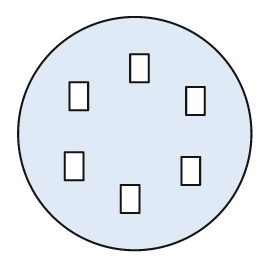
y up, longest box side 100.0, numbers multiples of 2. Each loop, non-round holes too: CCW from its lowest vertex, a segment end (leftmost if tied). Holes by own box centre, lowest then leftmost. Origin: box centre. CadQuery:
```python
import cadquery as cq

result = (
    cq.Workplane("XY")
    .moveTo(0.0, 0.0)
    .circle(50.0)
    .moveTo(-6.0, -34.0)
    .lineTo(2.0, -34.0)
    .lineTo(2.0, -22.0)
    .lineTo(-6.0, -22.0)
    .close()
    .moveTo(20.0, -22.0)
    .lineTo(28.0, -22.0)
    .lineTo(28.0, -10.0)
    .lineTo(20.0, -10.0)
    .close()
    .moveTo(-30.0, -20.0)
    .lineTo(-22.0, -20.0)
    .lineTo(-22.0, -8.0)
    .lineTo(-30.0, -8.0)
    .close()
    .moveTo(22.0, 8.0)
    .lineTo(30.0, 8.0)
    .lineTo(30.0, 20.0)
    .lineTo(22.0, 20.0)
    .close()
    .moveTo(-28.0, 10.0)
    .lineTo(-20.0, 10.0)
    .lineTo(-20.0, 22.0)
    .lineTo(-28.0, 22.0)
    .close()
    .moveTo(-2.0, 22.0)
    .lineTo(6.0, 22.0)
    .lineTo(6.0, 34.0)
    .lineTo(-2.0, 34.0)
    .close()
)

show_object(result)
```